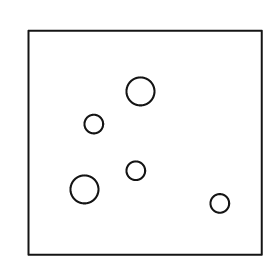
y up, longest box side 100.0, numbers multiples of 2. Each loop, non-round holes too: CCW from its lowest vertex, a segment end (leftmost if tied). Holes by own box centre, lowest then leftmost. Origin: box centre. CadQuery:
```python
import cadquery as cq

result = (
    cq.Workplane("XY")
    .moveTo(-50.0, -48.0)
    .lineTo(50.0, -48.0)
    .lineTo(50.0, 48.0)
    .lineTo(-50.0, 48.0)
    .close()
    .moveTo(32.0, -26.0)
    .circle(4.0)
    .moveTo(-26.0, -20.0)
    .circle(6.0)
    .moveTo(-4.0, -12.0)
    .circle(4.0)
    .moveTo(-22.0, 8.0)
    .circle(4.0)
    .moveTo(-2.0, 22.0)
    .circle(6.0)
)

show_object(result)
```